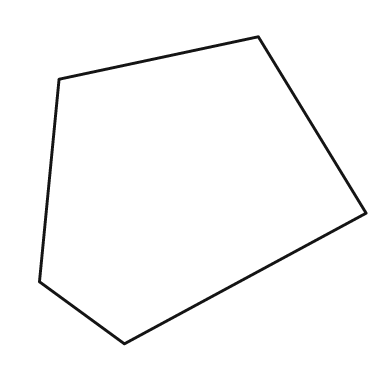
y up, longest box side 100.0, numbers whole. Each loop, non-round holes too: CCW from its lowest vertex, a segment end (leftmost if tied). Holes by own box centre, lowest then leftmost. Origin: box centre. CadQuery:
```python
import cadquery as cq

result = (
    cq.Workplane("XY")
    .moveTo(-24.0, -47.0)
    .lineTo(50.0, -7.0)
    .lineTo(17.0, 47.0)
    .lineTo(-44.0, 34.0)
    .lineTo(-50.0, -28.0)
    .close()
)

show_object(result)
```